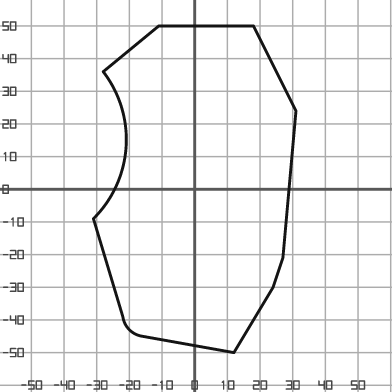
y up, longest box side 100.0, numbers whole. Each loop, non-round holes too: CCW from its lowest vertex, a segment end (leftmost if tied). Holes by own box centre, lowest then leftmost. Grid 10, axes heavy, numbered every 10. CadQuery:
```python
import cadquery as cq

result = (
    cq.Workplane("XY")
    .moveTo(12.0, -50.0)
    .lineTo(24.0, -30.0)
    .lineTo(27.0, -21.0)
    .lineTo(31.0, 24.0)
    .lineTo(18.0, 50.0)
    .lineTo(-11.0, 50.0)
    .lineTo(-28.0, 36.0)
    .threePointArc((-21.0, 13.0), (-31.0, -9.0))
    .lineTo(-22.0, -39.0)
    .threePointArc((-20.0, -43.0), (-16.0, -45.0))
    .close()
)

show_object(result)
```